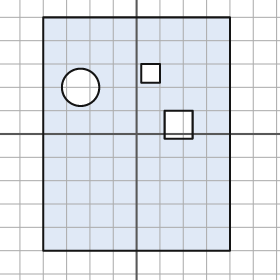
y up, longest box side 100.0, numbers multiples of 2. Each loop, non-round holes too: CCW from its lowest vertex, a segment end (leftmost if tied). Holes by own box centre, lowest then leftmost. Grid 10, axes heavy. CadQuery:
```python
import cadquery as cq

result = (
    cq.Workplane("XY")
    .moveTo(-40.0, -50.0)
    .lineTo(40.0, -50.0)
    .lineTo(40.0, 50.0)
    .lineTo(-40.0, 50.0)
    .close()
    .moveTo(12.0, -2.0)
    .lineTo(24.0, -2.0)
    .lineTo(24.0, 10.0)
    .lineTo(12.0, 10.0)
    .close()
    .moveTo(-24.0, 20.0)
    .circle(8.0)
    .moveTo(2.0, 22.0)
    .lineTo(10.0, 22.0)
    .lineTo(10.0, 30.0)
    .lineTo(2.0, 30.0)
    .close()
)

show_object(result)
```